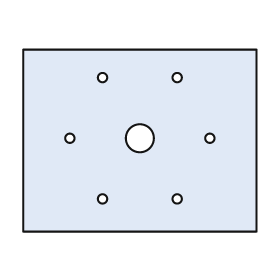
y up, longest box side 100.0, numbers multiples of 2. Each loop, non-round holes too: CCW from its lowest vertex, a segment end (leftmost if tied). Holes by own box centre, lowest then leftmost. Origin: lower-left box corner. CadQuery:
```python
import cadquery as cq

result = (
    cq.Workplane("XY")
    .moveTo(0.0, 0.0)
    .lineTo(100.0, 0.0)
    .lineTo(100.0, 78.0)
    .lineTo(0.0, 78.0)
    .close()
    .moveTo(34.0, 14.0)
    .circle(2.0)
    .moveTo(66.0, 14.0)
    .circle(2.0)
    .moveTo(20.0, 40.0)
    .circle(2.0)
    .moveTo(50.0, 40.0)
    .circle(6.0)
    .moveTo(80.0, 40.0)
    .circle(2.0)
    .moveTo(34.0, 66.0)
    .circle(2.0)
    .moveTo(66.0, 66.0)
    .circle(2.0)
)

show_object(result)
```